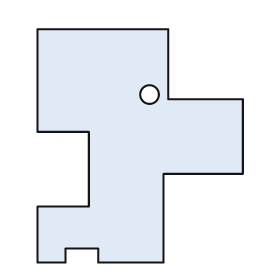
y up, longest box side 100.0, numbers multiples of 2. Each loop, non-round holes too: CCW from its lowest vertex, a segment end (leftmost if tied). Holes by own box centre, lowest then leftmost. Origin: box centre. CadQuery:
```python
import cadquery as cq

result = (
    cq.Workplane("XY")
    .moveTo(-44.0, -50.0)
    .lineTo(-32.0, -50.0)
    .lineTo(-32.0, -44.0)
    .lineTo(-18.0, -44.0)
    .lineTo(-18.0, -50.0)
    .lineTo(10.0, -50.0)
    .lineTo(10.0, -12.0)
    .lineTo(44.0, -12.0)
    .lineTo(44.0, 20.0)
    .lineTo(12.0, 20.0)
    .lineTo(12.0, 50.0)
    .lineTo(-44.0, 50.0)
    .lineTo(-44.0, 6.0)
    .lineTo(-22.0, 6.0)
    .lineTo(-22.0, -26.0)
    .lineTo(-44.0, -26.0)
    .close()
    .moveTo(4.0, 22.0)
    .circle(4.0)
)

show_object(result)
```